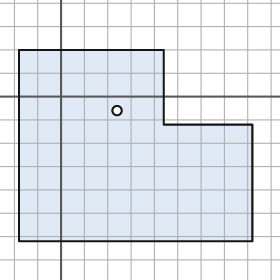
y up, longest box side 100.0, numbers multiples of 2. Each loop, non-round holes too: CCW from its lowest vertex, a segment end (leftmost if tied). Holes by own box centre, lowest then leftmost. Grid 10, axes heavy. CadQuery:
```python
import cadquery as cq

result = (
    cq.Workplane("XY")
    .moveTo(-18.0, -62.0)
    .lineTo(82.0, -62.0)
    .lineTo(82.0, -12.0)
    .lineTo(44.0, -12.0)
    .lineTo(44.0, 20.0)
    .lineTo(-18.0, 20.0)
    .close()
    .moveTo(24.0, -6.0)
    .circle(2.0)
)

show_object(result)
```